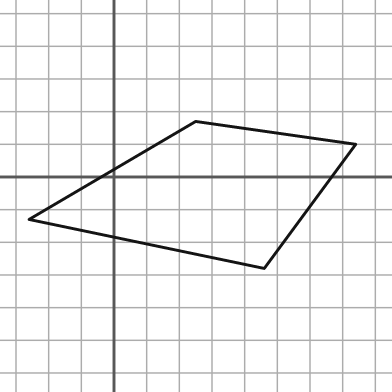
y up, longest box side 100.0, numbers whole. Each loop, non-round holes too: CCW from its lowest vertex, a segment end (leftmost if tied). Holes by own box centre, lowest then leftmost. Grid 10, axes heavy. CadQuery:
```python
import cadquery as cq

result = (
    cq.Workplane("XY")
    .moveTo(46.0, -28.0)
    .lineTo(74.0, 10.0)
    .lineTo(25.0, 17.0)
    .lineTo(-26.0, -13.0)
    .close()
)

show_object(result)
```